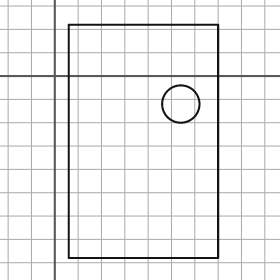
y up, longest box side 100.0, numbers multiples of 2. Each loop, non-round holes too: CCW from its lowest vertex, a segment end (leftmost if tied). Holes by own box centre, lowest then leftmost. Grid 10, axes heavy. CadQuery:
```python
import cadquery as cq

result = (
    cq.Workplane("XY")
    .moveTo(6.0, -78.0)
    .lineTo(70.0, -78.0)
    .lineTo(70.0, 22.0)
    .lineTo(6.0, 22.0)
    .close()
    .moveTo(54.0, -12.0)
    .circle(8.0)
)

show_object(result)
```